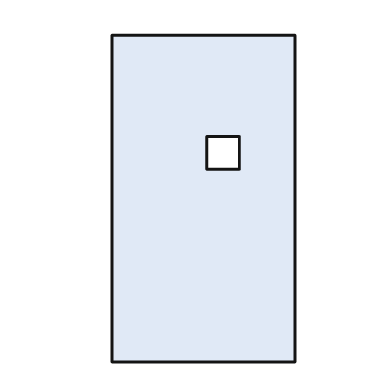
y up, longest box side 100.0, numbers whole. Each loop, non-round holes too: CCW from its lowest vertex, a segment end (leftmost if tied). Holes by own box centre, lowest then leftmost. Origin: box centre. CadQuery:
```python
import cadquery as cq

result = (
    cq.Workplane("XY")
    .moveTo(-28.0, -50.0)
    .lineTo(28.0, -50.0)
    .lineTo(28.0, 50.0)
    .lineTo(-28.0, 50.0)
    .close()
    .moveTo(1.0, 9.0)
    .lineTo(11.0, 9.0)
    .lineTo(11.0, 19.0)
    .lineTo(1.0, 19.0)
    .close()
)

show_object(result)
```